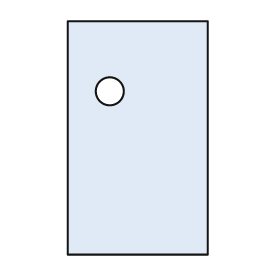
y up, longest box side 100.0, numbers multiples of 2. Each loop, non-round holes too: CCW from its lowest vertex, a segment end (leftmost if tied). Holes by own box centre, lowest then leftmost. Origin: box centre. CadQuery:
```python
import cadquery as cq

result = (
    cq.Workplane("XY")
    .moveTo(-30.0, -50.0)
    .lineTo(30.0, -50.0)
    .lineTo(30.0, 50.0)
    .lineTo(-30.0, 50.0)
    .close()
    .moveTo(-12.0, 20.0)
    .circle(6.0)
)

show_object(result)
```